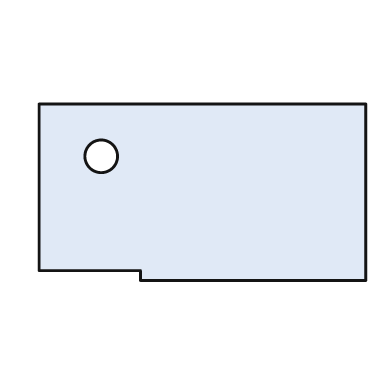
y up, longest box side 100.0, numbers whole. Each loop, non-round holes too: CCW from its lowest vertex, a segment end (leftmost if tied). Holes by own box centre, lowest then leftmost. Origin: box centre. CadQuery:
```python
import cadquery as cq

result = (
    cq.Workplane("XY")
    .moveTo(-19.0, -27.0)
    .lineTo(50.0, -27.0)
    .lineTo(50.0, 27.0)
    .lineTo(-50.0, 27.0)
    .lineTo(-50.0, -24.0)
    .lineTo(-19.0, -24.0)
    .close()
    .moveTo(-31.0, 11.0)
    .circle(5.0)
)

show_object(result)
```